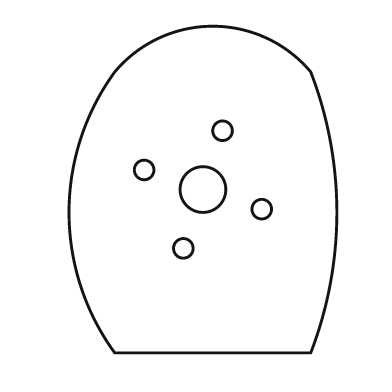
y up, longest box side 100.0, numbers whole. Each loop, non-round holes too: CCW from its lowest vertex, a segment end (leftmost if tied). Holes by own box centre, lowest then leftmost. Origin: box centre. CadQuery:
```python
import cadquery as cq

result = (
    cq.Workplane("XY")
    .moveTo(-27.0, -50.0)
    .lineTo(33.0, -50.0)
    .threePointArc((41.0, -7.0), (33.0, 36.0))
    .threePointArc((3.0, 50.0), (-27.0, 36.0))
    .threePointArc((-41.0, -7.0), (-27.0, -50.0))
    .close()
    .moveTo(-6.0, -18.0)
    .circle(3.0)
    .moveTo(18.0, -6.0)
    .circle(3.0)
    .moveTo(0.0, 0.0)
    .circle(7.0)
    .moveTo(-18.0, 6.0)
    .circle(3.0)
    .moveTo(6.0, 18.0)
    .circle(3.0)
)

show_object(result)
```